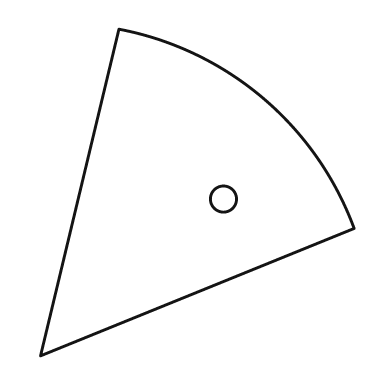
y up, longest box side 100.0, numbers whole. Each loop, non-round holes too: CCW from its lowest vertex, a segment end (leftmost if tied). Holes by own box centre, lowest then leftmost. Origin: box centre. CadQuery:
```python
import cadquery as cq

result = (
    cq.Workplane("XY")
    .moveTo(-48.0, -50.0)
    .lineTo(48.0, -11.0)
    .threePointArc((20.0, 29.0), (-24.0, 50.0))
    .close()
    .moveTo(8.0, -2.0)
    .circle(4.0)
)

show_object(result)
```